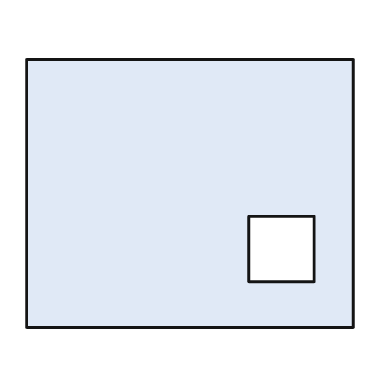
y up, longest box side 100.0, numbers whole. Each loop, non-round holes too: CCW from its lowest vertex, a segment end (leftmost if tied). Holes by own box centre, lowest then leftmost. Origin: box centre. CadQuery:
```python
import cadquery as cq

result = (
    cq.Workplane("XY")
    .moveTo(-50.0, -41.0)
    .lineTo(50.0, -41.0)
    .lineTo(50.0, 41.0)
    .lineTo(-50.0, 41.0)
    .close()
    .moveTo(18.0, -27.0)
    .lineTo(38.0, -27.0)
    .lineTo(38.0, -7.0)
    .lineTo(18.0, -7.0)
    .close()
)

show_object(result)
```